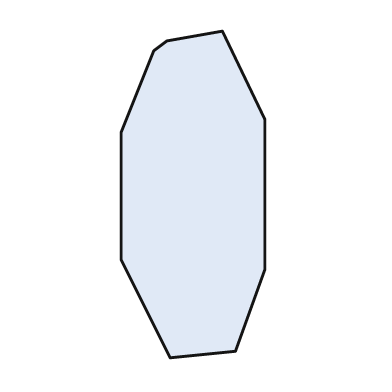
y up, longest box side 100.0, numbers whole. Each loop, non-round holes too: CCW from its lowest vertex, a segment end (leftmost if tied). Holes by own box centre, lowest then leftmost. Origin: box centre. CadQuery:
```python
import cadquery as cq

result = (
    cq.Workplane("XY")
    .moveTo(-7.0, -50.0)
    .lineTo(13.0, -48.0)
    .lineTo(22.0, -23.0)
    .lineTo(22.0, 23.0)
    .lineTo(9.0, 50.0)
    .lineTo(-8.0, 47.0)
    .lineTo(-12.0, 44.0)
    .lineTo(-22.0, 19.0)
    .lineTo(-22.0, -20.0)
    .close()
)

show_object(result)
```